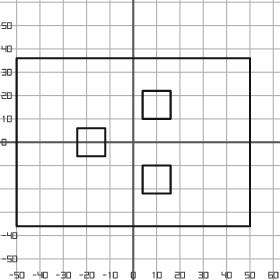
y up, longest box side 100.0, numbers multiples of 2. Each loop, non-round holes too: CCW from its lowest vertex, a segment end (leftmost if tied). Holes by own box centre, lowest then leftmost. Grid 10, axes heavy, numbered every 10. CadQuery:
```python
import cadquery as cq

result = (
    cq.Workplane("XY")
    .moveTo(-50.0, -36.0)
    .lineTo(50.0, -36.0)
    .lineTo(50.0, 36.0)
    .lineTo(-50.0, 36.0)
    .close()
    .moveTo(4.0, -22.0)
    .lineTo(16.0, -22.0)
    .lineTo(16.0, -10.0)
    .lineTo(4.0, -10.0)
    .close()
    .moveTo(-24.0, -6.0)
    .lineTo(-12.0, -6.0)
    .lineTo(-12.0, 6.0)
    .lineTo(-24.0, 6.0)
    .close()
    .moveTo(4.0, 10.0)
    .lineTo(16.0, 10.0)
    .lineTo(16.0, 22.0)
    .lineTo(4.0, 22.0)
    .close()
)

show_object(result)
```